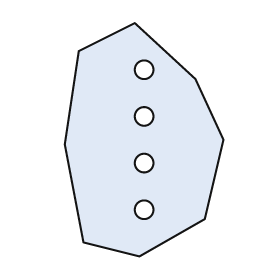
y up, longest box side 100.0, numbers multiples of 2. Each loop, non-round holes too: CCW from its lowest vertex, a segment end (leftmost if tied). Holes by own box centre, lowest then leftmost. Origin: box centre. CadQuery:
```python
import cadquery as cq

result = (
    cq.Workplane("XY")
    .moveTo(-2.0, -50.0)
    .lineTo(26.0, -34.0)
    .lineTo(34.0, 0.0)
    .lineTo(22.0, 26.0)
    .lineTo(-4.0, 50.0)
    .lineTo(-28.0, 38.0)
    .lineTo(-34.0, -2.0)
    .lineTo(-26.0, -44.0)
    .close()
    .moveTo(0.0, -30.0)
    .circle(4.0)
    .moveTo(0.0, -10.0)
    .circle(4.0)
    .moveTo(0.0, 10.0)
    .circle(4.0)
    .moveTo(0.0, 30.0)
    .circle(4.0)
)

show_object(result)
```